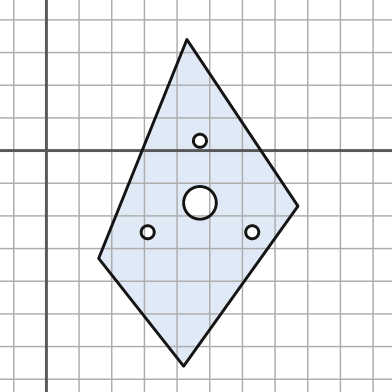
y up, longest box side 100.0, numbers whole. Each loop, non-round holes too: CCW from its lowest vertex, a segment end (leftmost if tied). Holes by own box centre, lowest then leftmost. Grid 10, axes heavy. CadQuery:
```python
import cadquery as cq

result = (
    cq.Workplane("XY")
    .moveTo(42.0, -66.0)
    .lineTo(77.0, -17.0)
    .lineTo(43.0, 34.0)
    .lineTo(16.0, -33.0)
    .close()
    .moveTo(31.0, -25.0)
    .circle(2.0)
    .moveTo(63.0, -25.0)
    .circle(2.0)
    .moveTo(47.0, -16.0)
    .circle(5.0)
    .moveTo(47.0, 3.0)
    .circle(2.0)
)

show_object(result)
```